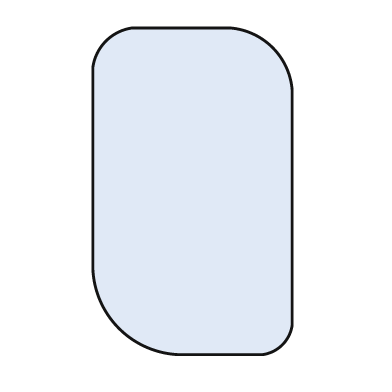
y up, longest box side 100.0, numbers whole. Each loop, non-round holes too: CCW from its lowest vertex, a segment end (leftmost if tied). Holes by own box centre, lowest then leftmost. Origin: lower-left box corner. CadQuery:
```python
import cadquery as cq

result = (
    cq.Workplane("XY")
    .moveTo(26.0, 0.0)
    .lineTo(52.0, 0.0)
    .threePointArc((58.0, 3.0), (61.0, 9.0))
    .lineTo(61.0, 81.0)
    .threePointArc((55.0, 94.0), (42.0, 100.0))
    .lineTo(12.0, 100.0)
    .threePointArc((4.0, 96.0), (0.0, 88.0))
    .lineTo(0.0, 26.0)
    .threePointArc((8.0, 8.0), (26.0, 0.0))
    .close()
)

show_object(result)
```